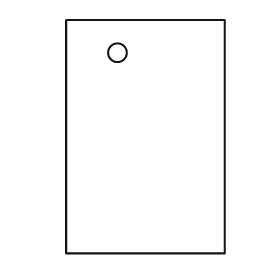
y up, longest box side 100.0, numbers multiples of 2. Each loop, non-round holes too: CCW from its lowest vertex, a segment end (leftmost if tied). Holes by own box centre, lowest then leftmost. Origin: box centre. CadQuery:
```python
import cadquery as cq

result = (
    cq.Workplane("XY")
    .moveTo(-34.0, -50.0)
    .lineTo(34.0, -50.0)
    .lineTo(34.0, 50.0)
    .lineTo(-34.0, 50.0)
    .close()
    .moveTo(-12.0, 36.0)
    .circle(4.0)
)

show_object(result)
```